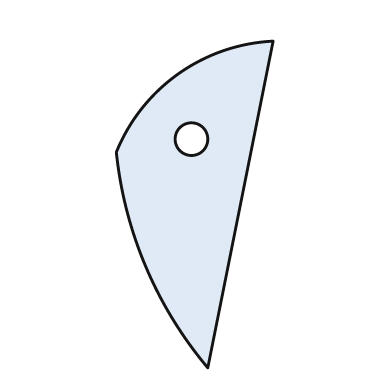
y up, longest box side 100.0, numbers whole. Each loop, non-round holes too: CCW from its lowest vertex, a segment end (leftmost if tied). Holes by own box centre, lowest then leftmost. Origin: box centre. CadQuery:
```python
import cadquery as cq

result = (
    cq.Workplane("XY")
    .moveTo(4.0, -50.0)
    .lineTo(24.0, 50.0)
    .threePointArc((-5.0, 40.0), (-24.0, 16.0))
    .threePointArc((-15.0, -19.0), (4.0, -50.0))
    .close()
    .moveTo(-1.0, 20.0)
    .circle(5.0)
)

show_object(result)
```